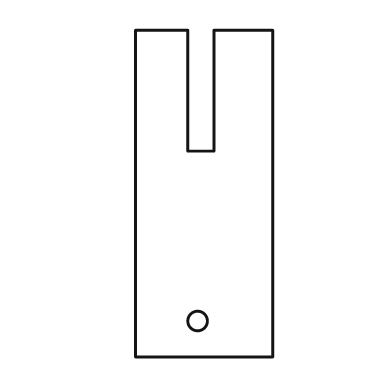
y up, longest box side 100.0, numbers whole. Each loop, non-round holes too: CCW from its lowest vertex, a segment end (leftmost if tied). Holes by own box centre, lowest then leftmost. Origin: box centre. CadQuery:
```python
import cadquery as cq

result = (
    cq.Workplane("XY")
    .moveTo(-21.0, -50.0)
    .lineTo(21.0, -50.0)
    .lineTo(21.0, 50.0)
    .lineTo(3.0, 50.0)
    .lineTo(3.0, 13.0)
    .lineTo(-5.0, 13.0)
    .lineTo(-5.0, 50.0)
    .lineTo(-21.0, 50.0)
    .close()
    .moveTo(-2.0, -39.0)
    .circle(3.0)
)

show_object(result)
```